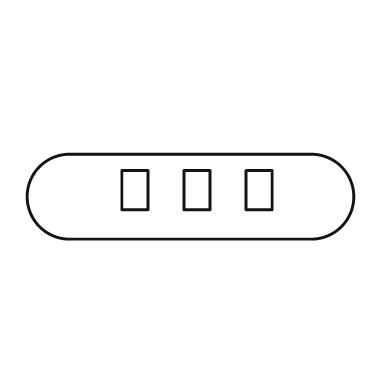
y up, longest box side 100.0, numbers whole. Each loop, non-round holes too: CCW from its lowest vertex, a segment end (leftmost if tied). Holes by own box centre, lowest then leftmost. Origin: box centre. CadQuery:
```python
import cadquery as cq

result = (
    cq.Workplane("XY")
    .moveTo(-37.0, -13.0)
    .lineTo(37.0, -13.0)
    .threePointArc((50.0, 0.0), (37.0, 13.0))
    .lineTo(-37.0, 13.0)
    .threePointArc((-50.0, 0.0), (-37.0, -13.0))
    .close()
    .moveTo(-21.0, -4.0)
    .lineTo(-13.0, -4.0)
    .lineTo(-13.0, 8.0)
    .lineTo(-21.0, 8.0)
    .close()
    .moveTo(-2.0, -4.0)
    .lineTo(6.0, -4.0)
    .lineTo(6.0, 8.0)
    .lineTo(-2.0, 8.0)
    .close()
    .moveTo(17.0, -4.0)
    .lineTo(25.0, -4.0)
    .lineTo(25.0, 8.0)
    .lineTo(17.0, 8.0)
    .close()
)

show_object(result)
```